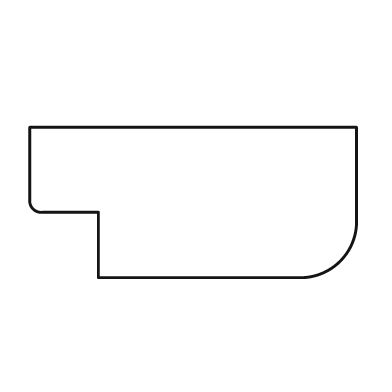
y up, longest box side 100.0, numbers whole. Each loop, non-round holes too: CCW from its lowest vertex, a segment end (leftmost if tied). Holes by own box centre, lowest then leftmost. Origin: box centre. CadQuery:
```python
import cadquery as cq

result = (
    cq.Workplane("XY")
    .moveTo(-29.0, -23.0)
    .lineTo(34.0, -23.0)
    .threePointArc((45.0, -18.0), (50.0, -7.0))
    .lineTo(50.0, 23.0)
    .lineTo(-50.0, 23.0)
    .lineTo(-50.0, 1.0)
    .threePointArc((-49.0, -2.0), (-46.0, -3.0))
    .lineTo(-29.0, -3.0)
    .close()
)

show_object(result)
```